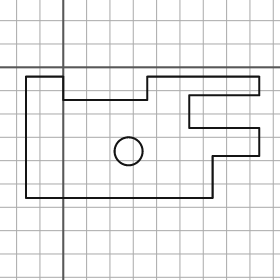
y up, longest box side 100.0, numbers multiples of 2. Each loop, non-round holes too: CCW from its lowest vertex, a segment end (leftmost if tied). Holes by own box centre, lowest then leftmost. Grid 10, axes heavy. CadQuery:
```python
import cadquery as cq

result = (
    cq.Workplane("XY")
    .moveTo(-16.0, -56.0)
    .lineTo(64.0, -56.0)
    .lineTo(64.0, -38.0)
    .lineTo(84.0, -38.0)
    .lineTo(84.0, -26.0)
    .lineTo(54.0, -26.0)
    .lineTo(54.0, -12.0)
    .lineTo(84.0, -12.0)
    .lineTo(84.0, -4.0)
    .lineTo(36.0, -4.0)
    .lineTo(36.0, -14.0)
    .lineTo(0.0, -14.0)
    .lineTo(0.0, -4.0)
    .lineTo(-16.0, -4.0)
    .close()
    .moveTo(28.0, -36.0)
    .circle(6.0)
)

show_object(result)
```